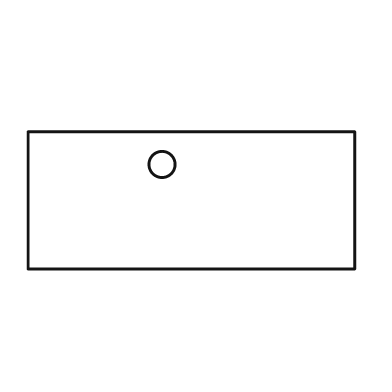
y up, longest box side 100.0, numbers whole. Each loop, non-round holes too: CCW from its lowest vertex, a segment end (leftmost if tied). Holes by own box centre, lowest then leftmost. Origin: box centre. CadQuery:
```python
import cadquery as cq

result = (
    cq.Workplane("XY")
    .moveTo(-50.0, -21.0)
    .lineTo(50.0, -21.0)
    .lineTo(50.0, 21.0)
    .lineTo(-50.0, 21.0)
    .close()
    .moveTo(-9.0, 11.0)
    .circle(4.0)
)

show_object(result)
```